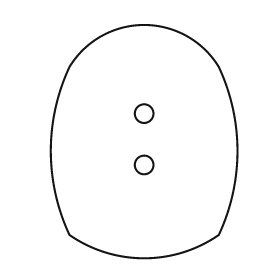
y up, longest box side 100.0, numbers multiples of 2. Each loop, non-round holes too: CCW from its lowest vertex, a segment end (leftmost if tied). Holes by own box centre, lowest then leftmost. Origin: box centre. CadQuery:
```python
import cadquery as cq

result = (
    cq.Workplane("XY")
    .moveTo(-32.0, -40.0)
    .threePointArc((0.0, -50.0), (32.0, -40.0))
    .threePointArc((40.0, -4.0), (32.0, 32.0))
    .threePointArc((0.0, 50.0), (-32.0, 32.0))
    .threePointArc((-40.0, -4.0), (-32.0, -40.0))
    .close()
    .moveTo(0.0, -10.0)
    .circle(4.0)
    .moveTo(0.0, 12.0)
    .circle(4.0)
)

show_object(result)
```